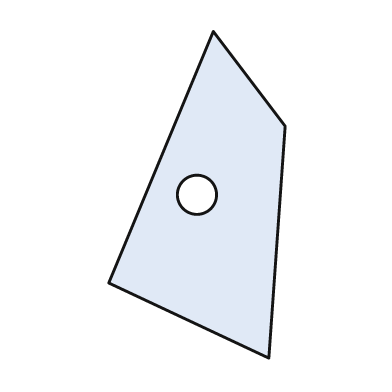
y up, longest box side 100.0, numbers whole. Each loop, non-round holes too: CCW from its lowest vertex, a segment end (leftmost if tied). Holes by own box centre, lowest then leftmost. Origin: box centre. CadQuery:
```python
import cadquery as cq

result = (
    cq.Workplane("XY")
    .moveTo(22.0, -50.0)
    .lineTo(27.0, 21.0)
    .lineTo(5.0, 50.0)
    .lineTo(-27.0, -27.0)
    .close()
    .moveTo(0.0, 0.0)
    .circle(6.0)
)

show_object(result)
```